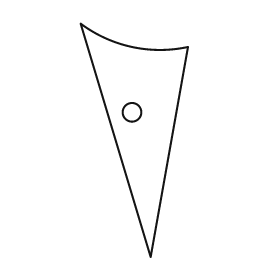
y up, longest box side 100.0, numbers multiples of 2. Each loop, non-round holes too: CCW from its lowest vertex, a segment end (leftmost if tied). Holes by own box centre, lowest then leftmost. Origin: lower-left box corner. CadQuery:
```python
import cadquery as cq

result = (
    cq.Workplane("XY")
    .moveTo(30.0, 0.0)
    .lineTo(46.0, 90.0)
    .threePointArc((22.0, 90.0), (0.0, 100.0))
    .close()
    .moveTo(22.0, 62.0)
    .circle(4.0)
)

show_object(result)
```